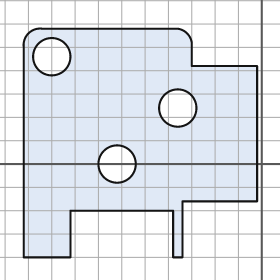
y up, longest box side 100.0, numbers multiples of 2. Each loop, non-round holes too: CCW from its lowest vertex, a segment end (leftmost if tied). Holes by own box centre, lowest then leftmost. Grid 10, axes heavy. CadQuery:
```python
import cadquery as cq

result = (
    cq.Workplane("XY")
    .moveTo(-102.0, -40.0)
    .lineTo(-82.0, -40.0)
    .lineTo(-82.0, -20.0)
    .lineTo(-38.0, -20.0)
    .lineTo(-38.0, -40.0)
    .lineTo(-34.0, -40.0)
    .lineTo(-34.0, -16.0)
    .lineTo(-2.0, -16.0)
    .lineTo(-2.0, 42.0)
    .lineTo(-30.0, 42.0)
    .lineTo(-30.0, 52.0)
    .threePointArc((-32.0, 56.0), (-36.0, 58.0))
    .lineTo(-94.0, 58.0)
    .threePointArc((-100.0, 56.0), (-102.0, 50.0))
    .close()
    .moveTo(-62.0, 0.0)
    .circle(8.0)
    .moveTo(-36.0, 24.0)
    .circle(8.0)
    .moveTo(-90.0, 46.0)
    .circle(8.0)
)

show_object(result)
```